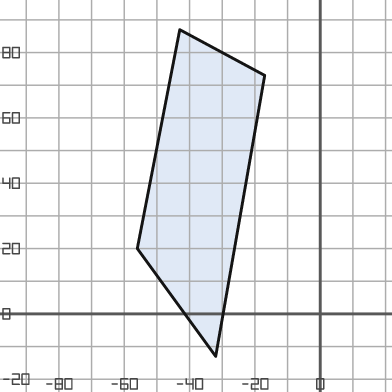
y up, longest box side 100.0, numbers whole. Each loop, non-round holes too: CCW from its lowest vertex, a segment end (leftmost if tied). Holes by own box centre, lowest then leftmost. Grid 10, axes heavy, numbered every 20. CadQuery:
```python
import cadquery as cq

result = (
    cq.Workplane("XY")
    .moveTo(-32.0, -13.0)
    .lineTo(-17.0, 73.0)
    .lineTo(-43.0, 87.0)
    .lineTo(-56.0, 20.0)
    .close()
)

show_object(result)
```